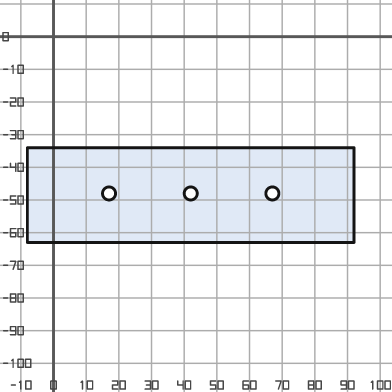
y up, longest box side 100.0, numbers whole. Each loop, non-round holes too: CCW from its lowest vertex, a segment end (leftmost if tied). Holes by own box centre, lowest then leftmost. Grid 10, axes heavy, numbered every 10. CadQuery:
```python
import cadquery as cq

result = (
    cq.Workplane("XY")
    .moveTo(-8.0, -63.0)
    .lineTo(92.0, -63.0)
    .lineTo(92.0, -34.0)
    .lineTo(-8.0, -34.0)
    .close()
    .moveTo(17.0, -48.0)
    .circle(2.0)
    .moveTo(42.0, -48.0)
    .circle(2.0)
    .moveTo(67.0, -48.0)
    .circle(2.0)
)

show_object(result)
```